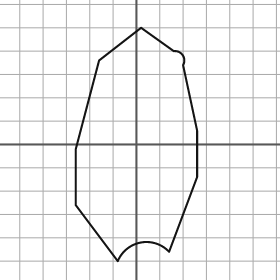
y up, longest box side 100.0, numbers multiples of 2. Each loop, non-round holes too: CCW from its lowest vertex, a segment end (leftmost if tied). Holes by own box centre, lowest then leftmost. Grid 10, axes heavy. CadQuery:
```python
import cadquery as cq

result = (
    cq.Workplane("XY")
    .moveTo(-8.0, -50.0)
    .threePointArc((2.0, -42.0), (14.0, -46.0))
    .lineTo(26.0, -14.0)
    .lineTo(26.0, 6.0)
    .lineTo(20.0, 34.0)
    .threePointArc((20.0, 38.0), (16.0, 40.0))
    .lineTo(2.0, 50.0)
    .lineTo(-16.0, 36.0)
    .lineTo(-26.0, -2.0)
    .lineTo(-26.0, -26.0)
    .close()
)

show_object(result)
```